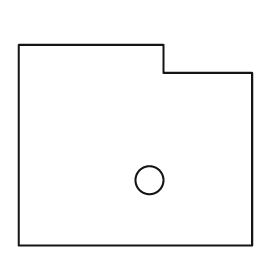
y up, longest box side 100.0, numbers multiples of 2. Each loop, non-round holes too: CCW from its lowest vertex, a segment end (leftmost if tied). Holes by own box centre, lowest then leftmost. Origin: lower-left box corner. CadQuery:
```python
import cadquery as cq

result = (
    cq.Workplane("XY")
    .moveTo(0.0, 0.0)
    .lineTo(100.0, 0.0)
    .lineTo(100.0, 74.0)
    .lineTo(62.0, 74.0)
    .lineTo(62.0, 86.0)
    .lineTo(0.0, 86.0)
    .close()
    .moveTo(56.0, 28.0)
    .circle(6.0)
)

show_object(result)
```